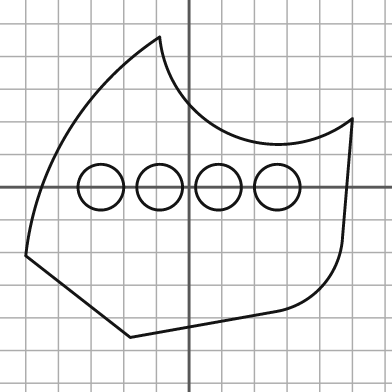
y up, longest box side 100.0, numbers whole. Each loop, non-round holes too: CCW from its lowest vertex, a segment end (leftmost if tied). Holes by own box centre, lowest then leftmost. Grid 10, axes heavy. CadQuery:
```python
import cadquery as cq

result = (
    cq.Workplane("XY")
    .moveTo(-18.0, -46.0)
    .lineTo(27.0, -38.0)
    .threePointArc((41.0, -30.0), (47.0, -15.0))
    .lineTo(50.0, 21.0)
    .threePointArc((13.0, 16.0), (-9.0, 46.0))
    .threePointArc((-37.0, 17.0), (-50.0, -21.0))
    .close()
    .moveTo(-27.0, 0.0)
    .circle(7.0)
    .moveTo(-9.0, 0.0)
    .circle(7.0)
    .moveTo(9.0, 0.0)
    .circle(7.0)
    .moveTo(27.0, 0.0)
    .circle(7.0)
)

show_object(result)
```